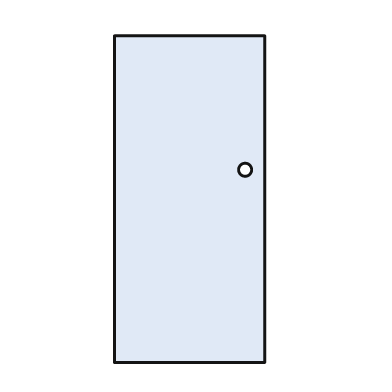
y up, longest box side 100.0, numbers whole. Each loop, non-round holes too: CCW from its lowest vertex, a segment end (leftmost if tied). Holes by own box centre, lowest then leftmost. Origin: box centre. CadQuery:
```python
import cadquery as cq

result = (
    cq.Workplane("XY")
    .moveTo(-23.0, -50.0)
    .lineTo(23.0, -50.0)
    .lineTo(23.0, 50.0)
    .lineTo(-23.0, 50.0)
    .close()
    .moveTo(17.0, 9.0)
    .circle(2.0)
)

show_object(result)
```